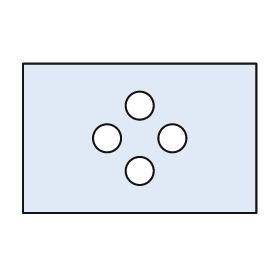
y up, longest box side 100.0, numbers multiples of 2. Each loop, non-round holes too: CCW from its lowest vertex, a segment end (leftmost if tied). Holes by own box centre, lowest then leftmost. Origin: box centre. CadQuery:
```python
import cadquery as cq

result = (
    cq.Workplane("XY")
    .moveTo(-50.0, -32.0)
    .lineTo(50.0, -32.0)
    .lineTo(50.0, 32.0)
    .lineTo(-50.0, 32.0)
    .close()
    .moveTo(0.0, -14.0)
    .circle(6.0)
    .moveTo(-14.0, 0.0)
    .circle(6.0)
    .moveTo(14.0, 0.0)
    .circle(6.0)
    .moveTo(0.0, 14.0)
    .circle(6.0)
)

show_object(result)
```